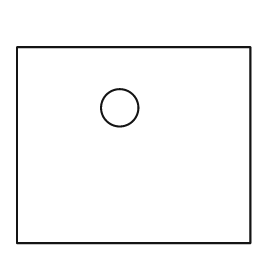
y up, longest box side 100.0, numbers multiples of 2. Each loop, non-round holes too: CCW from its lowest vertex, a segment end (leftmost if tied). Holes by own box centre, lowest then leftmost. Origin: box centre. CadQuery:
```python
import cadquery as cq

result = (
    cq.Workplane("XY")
    .moveTo(-50.0, -42.0)
    .lineTo(50.0, -42.0)
    .lineTo(50.0, 42.0)
    .lineTo(-50.0, 42.0)
    .close()
    .moveTo(-6.0, 16.0)
    .circle(8.0)
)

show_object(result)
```